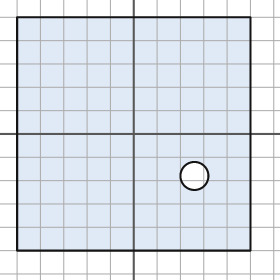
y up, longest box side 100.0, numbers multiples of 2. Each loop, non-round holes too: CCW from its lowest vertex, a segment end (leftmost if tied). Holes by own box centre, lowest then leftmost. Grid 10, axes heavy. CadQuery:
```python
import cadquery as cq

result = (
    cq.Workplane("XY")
    .moveTo(-50.0, -50.0)
    .lineTo(50.0, -50.0)
    .lineTo(50.0, 50.0)
    .lineTo(-50.0, 50.0)
    .close()
    .moveTo(26.0, -18.0)
    .circle(6.0)
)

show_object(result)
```